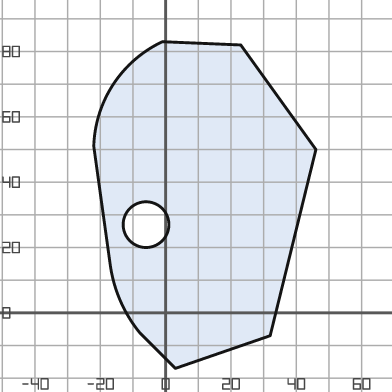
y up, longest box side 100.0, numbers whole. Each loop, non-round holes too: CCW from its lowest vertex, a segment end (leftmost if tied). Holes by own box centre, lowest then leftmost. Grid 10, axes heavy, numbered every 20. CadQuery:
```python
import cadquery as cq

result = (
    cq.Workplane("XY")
    .moveTo(3.0, -17.0)
    .lineTo(32.0, -7.0)
    .lineTo(46.0, 50.0)
    .lineTo(23.0, 82.0)
    .lineTo(-1.0, 83.0)
    .threePointArc((-16.0, 70.0), (-22.0, 51.0))
    .lineTo(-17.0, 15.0)
    .threePointArc((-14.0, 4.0), (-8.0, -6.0))
    .close()
    .moveTo(-6.0, 27.0)
    .circle(7.0)
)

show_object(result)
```